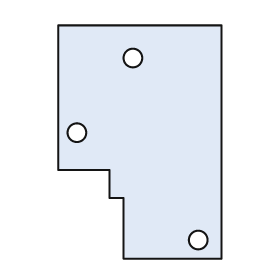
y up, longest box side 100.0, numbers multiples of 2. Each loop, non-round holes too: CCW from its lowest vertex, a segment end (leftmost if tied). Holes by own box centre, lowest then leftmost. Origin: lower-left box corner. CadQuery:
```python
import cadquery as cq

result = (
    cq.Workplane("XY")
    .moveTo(28.0, 0.0)
    .lineTo(70.0, 0.0)
    .lineTo(70.0, 100.0)
    .lineTo(0.0, 100.0)
    .lineTo(0.0, 38.0)
    .lineTo(22.0, 38.0)
    .lineTo(22.0, 26.0)
    .lineTo(28.0, 26.0)
    .close()
    .moveTo(60.0, 8.0)
    .circle(4.0)
    .moveTo(8.0, 54.0)
    .circle(4.0)
    .moveTo(32.0, 86.0)
    .circle(4.0)
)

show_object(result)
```